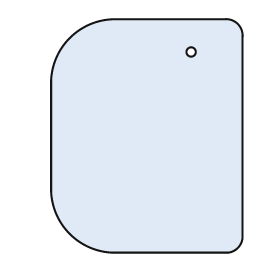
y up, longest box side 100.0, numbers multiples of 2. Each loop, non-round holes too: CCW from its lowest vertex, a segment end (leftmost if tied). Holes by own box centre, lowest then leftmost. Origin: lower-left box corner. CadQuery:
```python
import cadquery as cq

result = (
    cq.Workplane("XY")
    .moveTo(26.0, 0.0)
    .lineTo(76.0, 0.0)
    .threePointArc((80.0, 2.0), (82.0, 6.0))
    .lineTo(82.0, 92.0)
    .threePointArc((80.0, 98.0), (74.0, 100.0))
    .lineTo(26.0, 100.0)
    .threePointArc((8.0, 92.0), (0.0, 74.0))
    .lineTo(0.0, 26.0)
    .threePointArc((8.0, 8.0), (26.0, 0.0))
    .close()
    .moveTo(60.0, 86.0)
    .circle(2.0)
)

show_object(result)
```